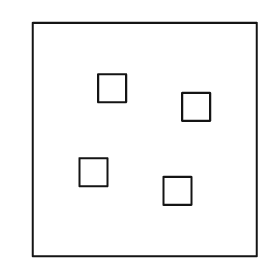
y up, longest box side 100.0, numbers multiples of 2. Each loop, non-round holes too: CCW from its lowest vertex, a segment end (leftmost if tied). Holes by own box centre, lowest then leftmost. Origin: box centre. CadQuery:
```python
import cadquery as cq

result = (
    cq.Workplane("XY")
    .moveTo(-48.0, -50.0)
    .lineTo(48.0, -50.0)
    .lineTo(48.0, 50.0)
    .lineTo(-48.0, 50.0)
    .close()
    .moveTo(8.0, -28.0)
    .lineTo(20.0, -28.0)
    .lineTo(20.0, -16.0)
    .lineTo(8.0, -16.0)
    .close()
    .moveTo(-28.0, -20.0)
    .lineTo(-16.0, -20.0)
    .lineTo(-16.0, -8.0)
    .lineTo(-28.0, -8.0)
    .close()
    .moveTo(16.0, 8.0)
    .lineTo(28.0, 8.0)
    .lineTo(28.0, 20.0)
    .lineTo(16.0, 20.0)
    .close()
    .moveTo(-20.0, 16.0)
    .lineTo(-8.0, 16.0)
    .lineTo(-8.0, 28.0)
    .lineTo(-20.0, 28.0)
    .close()
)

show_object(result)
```